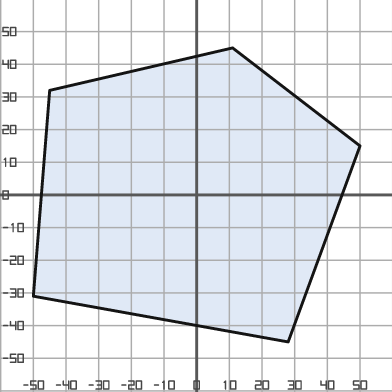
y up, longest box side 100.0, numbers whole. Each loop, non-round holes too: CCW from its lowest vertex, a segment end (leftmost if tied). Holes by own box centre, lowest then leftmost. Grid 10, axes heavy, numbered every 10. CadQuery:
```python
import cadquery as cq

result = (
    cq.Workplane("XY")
    .moveTo(28.0, -45.0)
    .lineTo(50.0, 15.0)
    .lineTo(11.0, 45.0)
    .lineTo(-45.0, 32.0)
    .lineTo(-50.0, -31.0)
    .close()
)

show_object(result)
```